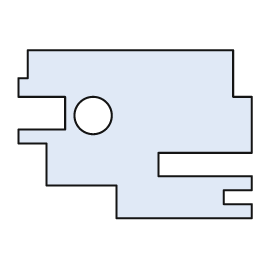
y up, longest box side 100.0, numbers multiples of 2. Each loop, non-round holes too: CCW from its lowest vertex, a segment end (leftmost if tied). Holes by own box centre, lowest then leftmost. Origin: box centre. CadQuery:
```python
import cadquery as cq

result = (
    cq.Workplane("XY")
    .moveTo(-8.0, -36.0)
    .lineTo(50.0, -36.0)
    .lineTo(50.0, -30.0)
    .lineTo(38.0, -30.0)
    .lineTo(38.0, -24.0)
    .lineTo(50.0, -24.0)
    .lineTo(50.0, -18.0)
    .lineTo(10.0, -18.0)
    .lineTo(10.0, -8.0)
    .lineTo(50.0, -8.0)
    .lineTo(50.0, 16.0)
    .lineTo(42.0, 16.0)
    .lineTo(42.0, 36.0)
    .lineTo(-46.0, 36.0)
    .lineTo(-46.0, 24.0)
    .lineTo(-50.0, 24.0)
    .lineTo(-50.0, 16.0)
    .lineTo(-30.0, 16.0)
    .lineTo(-30.0, 2.0)
    .lineTo(-50.0, 2.0)
    .lineTo(-50.0, -4.0)
    .lineTo(-38.0, -4.0)
    .lineTo(-38.0, -22.0)
    .lineTo(-8.0, -22.0)
    .close()
    .moveTo(-18.0, 8.0)
    .circle(8.0)
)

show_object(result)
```